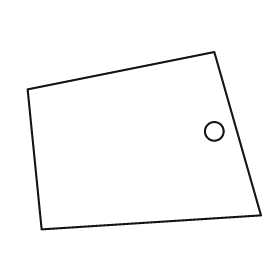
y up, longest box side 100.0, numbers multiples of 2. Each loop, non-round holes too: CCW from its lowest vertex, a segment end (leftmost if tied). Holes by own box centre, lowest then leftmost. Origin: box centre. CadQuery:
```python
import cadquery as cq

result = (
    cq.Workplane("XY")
    .moveTo(-44.0, -38.0)
    .lineTo(50.0, -32.0)
    .lineTo(30.0, 38.0)
    .lineTo(-50.0, 22.0)
    .close()
    .moveTo(30.0, 4.0)
    .circle(4.0)
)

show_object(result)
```